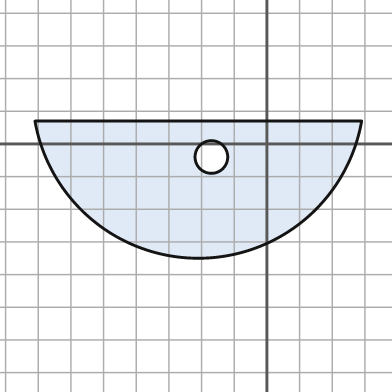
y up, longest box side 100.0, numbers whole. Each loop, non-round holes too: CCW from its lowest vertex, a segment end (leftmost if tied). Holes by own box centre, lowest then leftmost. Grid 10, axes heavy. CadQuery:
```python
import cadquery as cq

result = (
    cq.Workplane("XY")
    .moveTo(-71.0, 7.0)
    .threePointArc((-21.0, -35.0), (29.0, 7.0))
    .close()
    .moveTo(-17.0, -4.0)
    .circle(5.0)
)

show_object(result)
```